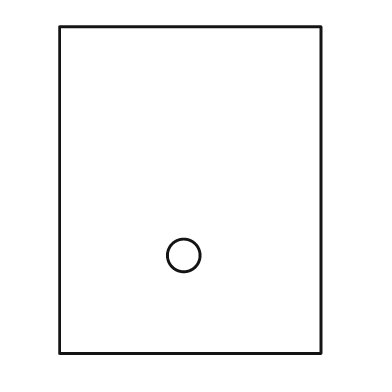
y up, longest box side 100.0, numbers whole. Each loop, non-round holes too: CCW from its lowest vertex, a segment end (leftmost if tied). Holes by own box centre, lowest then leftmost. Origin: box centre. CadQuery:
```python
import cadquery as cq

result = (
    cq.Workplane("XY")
    .moveTo(-40.0, -50.0)
    .lineTo(40.0, -50.0)
    .lineTo(40.0, 50.0)
    .lineTo(-40.0, 50.0)
    .close()
    .moveTo(-2.0, -20.0)
    .circle(5.0)
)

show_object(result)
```